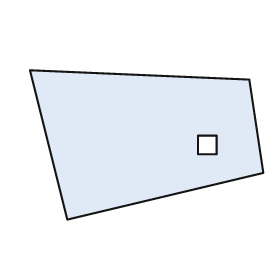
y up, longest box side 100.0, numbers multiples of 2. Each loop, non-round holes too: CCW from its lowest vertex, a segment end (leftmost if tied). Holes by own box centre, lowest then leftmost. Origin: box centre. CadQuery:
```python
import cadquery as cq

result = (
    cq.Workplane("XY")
    .moveTo(-34.0, -32.0)
    .lineTo(50.0, -12.0)
    .lineTo(44.0, 28.0)
    .lineTo(-50.0, 32.0)
    .close()
    .moveTo(22.0, -4.0)
    .lineTo(30.0, -4.0)
    .lineTo(30.0, 4.0)
    .lineTo(22.0, 4.0)
    .close()
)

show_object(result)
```